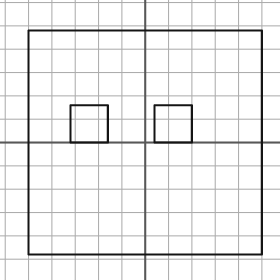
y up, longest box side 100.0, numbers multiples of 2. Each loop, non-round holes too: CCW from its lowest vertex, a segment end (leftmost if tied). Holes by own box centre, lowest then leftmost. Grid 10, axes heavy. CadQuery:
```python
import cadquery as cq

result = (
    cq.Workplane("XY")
    .moveTo(-50.0, -48.0)
    .lineTo(50.0, -48.0)
    .lineTo(50.0, 48.0)
    .lineTo(-50.0, 48.0)
    .close()
    .moveTo(-32.0, 0.0)
    .lineTo(-16.0, 0.0)
    .lineTo(-16.0, 16.0)
    .lineTo(-32.0, 16.0)
    .close()
    .moveTo(4.0, 0.0)
    .lineTo(20.0, 0.0)
    .lineTo(20.0, 16.0)
    .lineTo(4.0, 16.0)
    .close()
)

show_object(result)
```